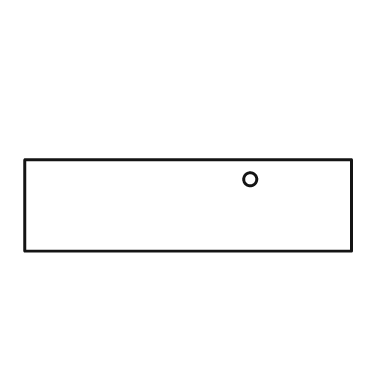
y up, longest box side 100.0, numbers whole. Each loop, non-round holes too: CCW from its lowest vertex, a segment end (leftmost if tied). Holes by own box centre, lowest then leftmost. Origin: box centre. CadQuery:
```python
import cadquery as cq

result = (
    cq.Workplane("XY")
    .moveTo(-50.0, -14.0)
    .lineTo(50.0, -14.0)
    .lineTo(50.0, 14.0)
    .lineTo(-50.0, 14.0)
    .close()
    .moveTo(19.0, 8.0)
    .circle(2.0)
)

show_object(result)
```